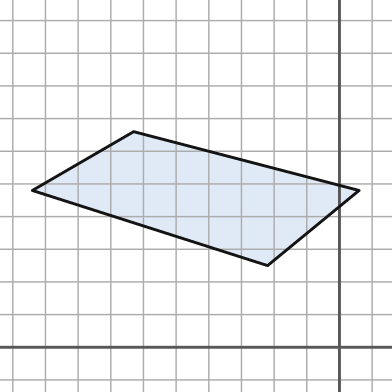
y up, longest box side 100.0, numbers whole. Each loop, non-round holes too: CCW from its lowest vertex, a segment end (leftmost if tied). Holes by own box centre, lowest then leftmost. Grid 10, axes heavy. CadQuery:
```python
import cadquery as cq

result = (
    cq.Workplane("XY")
    .moveTo(-22.0, 25.0)
    .lineTo(6.0, 48.0)
    .lineTo(-63.0, 66.0)
    .lineTo(-94.0, 48.0)
    .close()
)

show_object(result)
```